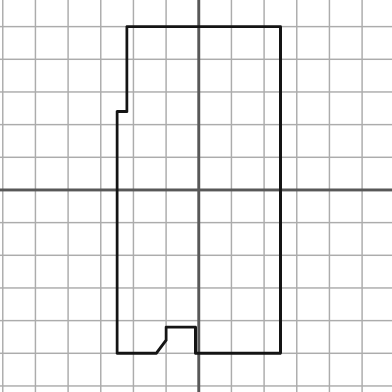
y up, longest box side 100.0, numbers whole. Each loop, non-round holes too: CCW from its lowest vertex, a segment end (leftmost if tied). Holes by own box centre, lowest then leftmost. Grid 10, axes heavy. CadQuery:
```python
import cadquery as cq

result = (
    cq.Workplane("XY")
    .moveTo(-25.0, -50.0)
    .lineTo(-13.0, -50.0)
    .lineTo(-10.0, -46.0)
    .lineTo(-10.0, -42.0)
    .lineTo(-1.0, -42.0)
    .lineTo(-1.0, -50.0)
    .lineTo(25.0, -50.0)
    .lineTo(25.0, 50.0)
    .lineTo(-22.0, 50.0)
    .lineTo(-22.0, 24.0)
    .lineTo(-25.0, 24.0)
    .close()
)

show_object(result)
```